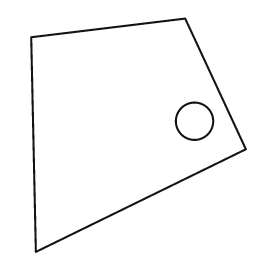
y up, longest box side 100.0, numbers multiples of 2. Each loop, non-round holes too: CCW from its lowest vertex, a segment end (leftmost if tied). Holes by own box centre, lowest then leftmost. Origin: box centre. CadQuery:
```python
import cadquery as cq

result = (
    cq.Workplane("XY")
    .moveTo(-44.0, -50.0)
    .lineTo(46.0, -6.0)
    .lineTo(20.0, 50.0)
    .lineTo(-46.0, 42.0)
    .close()
    .moveTo(24.0, 6.0)
    .circle(8.0)
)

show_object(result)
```